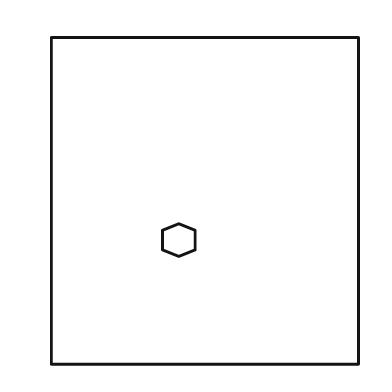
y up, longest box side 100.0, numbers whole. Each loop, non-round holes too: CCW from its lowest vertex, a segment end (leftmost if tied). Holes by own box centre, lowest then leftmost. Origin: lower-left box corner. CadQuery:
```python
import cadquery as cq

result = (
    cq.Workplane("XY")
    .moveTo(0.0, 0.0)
    .lineTo(94.0, 0.0)
    .lineTo(94.0, 100.0)
    .lineTo(0.0, 100.0)
    .close()
    .moveTo(39.0, 33.0)
    .lineTo(44.0, 35.0)
    .lineTo(44.0, 41.0)
    .lineTo(39.0, 43.0)
    .lineTo(34.0, 41.0)
    .lineTo(34.0, 35.0)
    .close()
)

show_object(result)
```